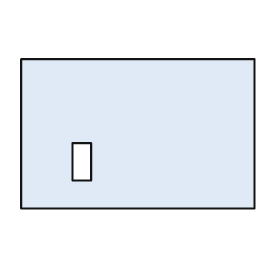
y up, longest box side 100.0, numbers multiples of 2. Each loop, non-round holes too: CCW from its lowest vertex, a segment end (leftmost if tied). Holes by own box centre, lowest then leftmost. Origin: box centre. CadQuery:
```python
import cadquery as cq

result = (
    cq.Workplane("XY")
    .moveTo(-50.0, -32.0)
    .lineTo(50.0, -32.0)
    .lineTo(50.0, 32.0)
    .lineTo(-50.0, 32.0)
    .close()
    .moveTo(-28.0, -20.0)
    .lineTo(-20.0, -20.0)
    .lineTo(-20.0, -4.0)
    .lineTo(-28.0, -4.0)
    .close()
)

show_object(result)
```